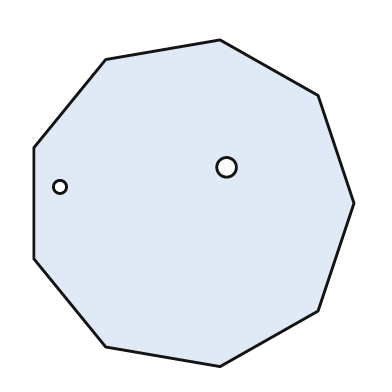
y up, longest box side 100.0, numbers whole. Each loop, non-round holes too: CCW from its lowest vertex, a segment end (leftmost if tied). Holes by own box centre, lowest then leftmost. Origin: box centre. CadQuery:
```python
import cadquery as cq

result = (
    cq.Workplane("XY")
    .moveTo(8.0, -50.0)
    .lineTo(38.0, -33.0)
    .lineTo(49.0, 0.0)
    .lineTo(38.0, 33.0)
    .lineTo(8.0, 50.0)
    .lineTo(-27.0, 44.0)
    .lineTo(-49.0, 17.0)
    .lineTo(-49.0, -17.0)
    .lineTo(-27.0, -44.0)
    .close()
    .moveTo(-41.0, 5.0)
    .circle(2.0)
    .moveTo(10.0, 11.0)
    .circle(3.0)
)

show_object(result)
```